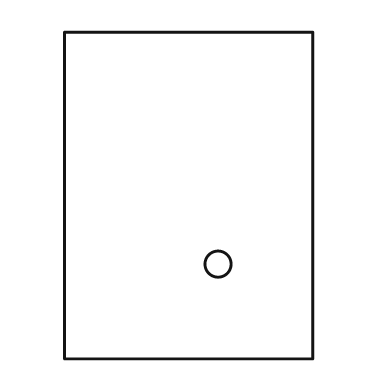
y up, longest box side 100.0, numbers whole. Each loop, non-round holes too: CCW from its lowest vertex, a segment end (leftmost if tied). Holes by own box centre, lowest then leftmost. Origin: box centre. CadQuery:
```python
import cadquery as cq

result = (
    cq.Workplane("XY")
    .moveTo(-38.0, -50.0)
    .lineTo(38.0, -50.0)
    .lineTo(38.0, 50.0)
    .lineTo(-38.0, 50.0)
    .close()
    .moveTo(9.0, -21.0)
    .circle(4.0)
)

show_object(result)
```